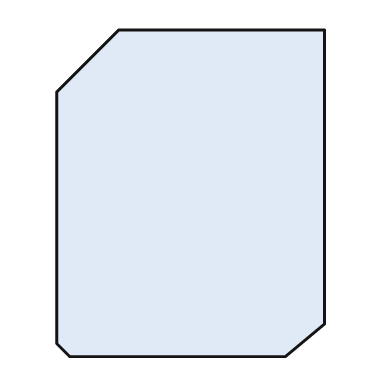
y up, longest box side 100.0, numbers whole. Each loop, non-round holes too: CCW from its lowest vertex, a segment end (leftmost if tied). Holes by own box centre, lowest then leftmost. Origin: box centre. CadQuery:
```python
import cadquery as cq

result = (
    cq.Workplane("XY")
    .moveTo(-37.0, -50.0)
    .lineTo(29.0, -50.0)
    .lineTo(41.0, -40.0)
    .lineTo(41.0, 50.0)
    .lineTo(-22.0, 50.0)
    .lineTo(-41.0, 31.0)
    .lineTo(-41.0, -46.0)
    .close()
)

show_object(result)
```